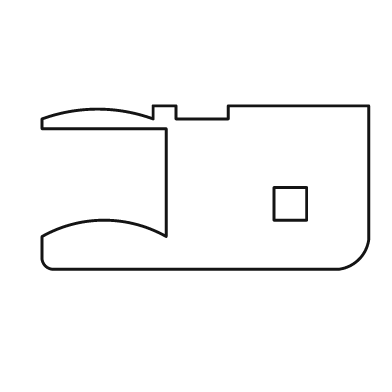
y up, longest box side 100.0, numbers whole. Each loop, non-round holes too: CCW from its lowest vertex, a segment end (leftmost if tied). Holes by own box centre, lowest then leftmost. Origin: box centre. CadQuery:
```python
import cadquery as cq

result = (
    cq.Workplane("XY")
    .moveTo(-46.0, -25.0)
    .lineTo(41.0, -25.0)
    .threePointArc((47.0, -22.0), (50.0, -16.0))
    .lineTo(50.0, 25.0)
    .lineTo(7.0, 25.0)
    .lineTo(7.0, 21.0)
    .lineTo(-9.0, 21.0)
    .lineTo(-9.0, 25.0)
    .lineTo(-16.0, 25.0)
    .lineTo(-16.0, 21.0)
    .threePointArc((-33.0, 24.0), (-50.0, 21.0))
    .lineTo(-50.0, 18.0)
    .lineTo(-12.0, 18.0)
    .lineTo(-12.0, -15.0)
    .threePointArc((-31.0, -10.0), (-50.0, -15.0))
    .lineTo(-50.0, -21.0)
    .threePointArc((-49.0, -24.0), (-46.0, -25.0))
    .close()
    .moveTo(21.0, -10.0)
    .lineTo(31.0, -10.0)
    .lineTo(31.0, 0.0)
    .lineTo(21.0, 0.0)
    .close()
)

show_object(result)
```